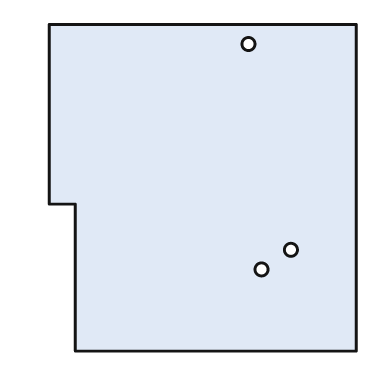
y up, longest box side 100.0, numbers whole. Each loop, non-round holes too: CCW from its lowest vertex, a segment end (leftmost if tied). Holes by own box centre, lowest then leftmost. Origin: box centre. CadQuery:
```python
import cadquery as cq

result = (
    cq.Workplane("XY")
    .moveTo(-39.0, -50.0)
    .lineTo(47.0, -50.0)
    .lineTo(47.0, 50.0)
    .lineTo(-47.0, 50.0)
    .lineTo(-47.0, -5.0)
    .lineTo(-39.0, -5.0)
    .close()
    .moveTo(18.0, -25.0)
    .circle(2.0)
    .moveTo(27.0, -19.0)
    .circle(2.0)
    .moveTo(14.0, 44.0)
    .circle(2.0)
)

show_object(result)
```